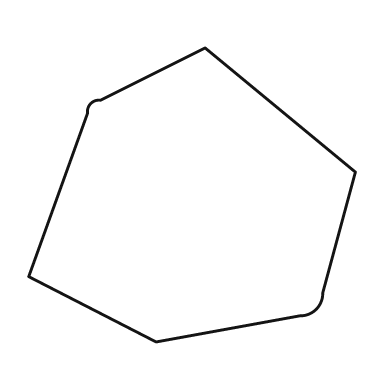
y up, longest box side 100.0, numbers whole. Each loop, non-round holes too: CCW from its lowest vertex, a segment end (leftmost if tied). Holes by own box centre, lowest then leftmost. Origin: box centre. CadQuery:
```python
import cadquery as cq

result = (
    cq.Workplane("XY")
    .moveTo(-11.0, -45.0)
    .lineTo(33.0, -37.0)
    .threePointArc((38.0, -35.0), (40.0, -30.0))
    .lineTo(50.0, 7.0)
    .lineTo(4.0, 45.0)
    .lineTo(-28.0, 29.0)
    .threePointArc((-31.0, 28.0), (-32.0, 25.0))
    .lineTo(-50.0, -25.0)
    .close()
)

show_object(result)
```